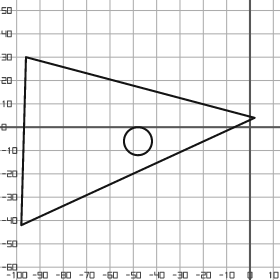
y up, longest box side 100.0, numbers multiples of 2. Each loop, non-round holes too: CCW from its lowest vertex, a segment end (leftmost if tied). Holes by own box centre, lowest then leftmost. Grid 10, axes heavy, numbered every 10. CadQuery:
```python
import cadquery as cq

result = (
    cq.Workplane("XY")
    .moveTo(-98.0, -42.0)
    .lineTo(2.0, 4.0)
    .lineTo(-96.0, 30.0)
    .close()
    .moveTo(-48.0, -6.0)
    .circle(6.0)
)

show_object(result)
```